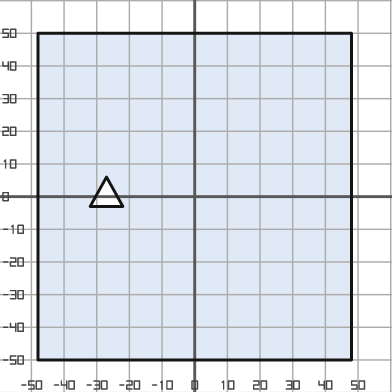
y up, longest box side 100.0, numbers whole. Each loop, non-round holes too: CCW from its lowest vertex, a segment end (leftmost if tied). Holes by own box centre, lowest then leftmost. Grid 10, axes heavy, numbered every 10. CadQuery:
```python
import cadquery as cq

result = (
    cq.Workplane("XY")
    .moveTo(-48.0, -50.0)
    .lineTo(48.0, -50.0)
    .lineTo(48.0, 50.0)
    .lineTo(-48.0, 50.0)
    .close()
    .moveTo(-32.0, -3.0)
    .lineTo(-22.0, -3.0)
    .lineTo(-27.0, 6.0)
    .close()
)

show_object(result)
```